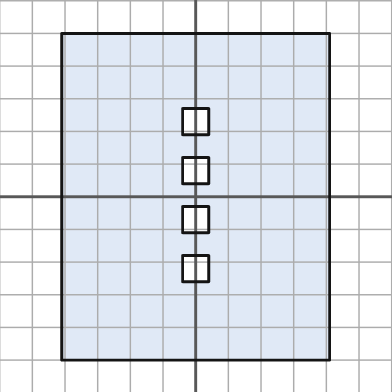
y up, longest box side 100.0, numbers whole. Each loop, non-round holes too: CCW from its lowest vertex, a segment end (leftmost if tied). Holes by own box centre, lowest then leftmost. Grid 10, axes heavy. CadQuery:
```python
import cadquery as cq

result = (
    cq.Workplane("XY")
    .moveTo(-41.0, -50.0)
    .lineTo(41.0, -50.0)
    .lineTo(41.0, 50.0)
    .lineTo(-41.0, 50.0)
    .close()
    .moveTo(-4.0, -26.0)
    .lineTo(4.0, -26.0)
    .lineTo(4.0, -18.0)
    .lineTo(-4.0, -18.0)
    .close()
    .moveTo(-4.0, -11.0)
    .lineTo(4.0, -11.0)
    .lineTo(4.0, -3.0)
    .lineTo(-4.0, -3.0)
    .close()
    .moveTo(-4.0, 4.0)
    .lineTo(4.0, 4.0)
    .lineTo(4.0, 12.0)
    .lineTo(-4.0, 12.0)
    .close()
    .moveTo(-4.0, 19.0)
    .lineTo(4.0, 19.0)
    .lineTo(4.0, 27.0)
    .lineTo(-4.0, 27.0)
    .close()
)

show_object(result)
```